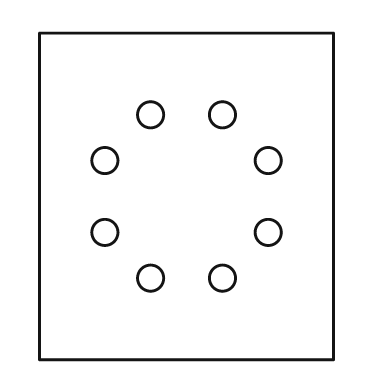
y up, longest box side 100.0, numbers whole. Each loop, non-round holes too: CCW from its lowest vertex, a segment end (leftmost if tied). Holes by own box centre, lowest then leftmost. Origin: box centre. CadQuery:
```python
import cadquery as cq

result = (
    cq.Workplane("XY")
    .moveTo(-45.0, -50.0)
    .lineTo(45.0, -50.0)
    .lineTo(45.0, 50.0)
    .lineTo(-45.0, 50.0)
    .close()
    .moveTo(-11.0, -25.0)
    .circle(4.0)
    .moveTo(11.0, -25.0)
    .circle(4.0)
    .moveTo(-25.0, -11.0)
    .circle(4.0)
    .moveTo(25.0, -11.0)
    .circle(4.0)
    .moveTo(-25.0, 11.0)
    .circle(4.0)
    .moveTo(25.0, 11.0)
    .circle(4.0)
    .moveTo(-11.0, 25.0)
    .circle(4.0)
    .moveTo(11.0, 25.0)
    .circle(4.0)
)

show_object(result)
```